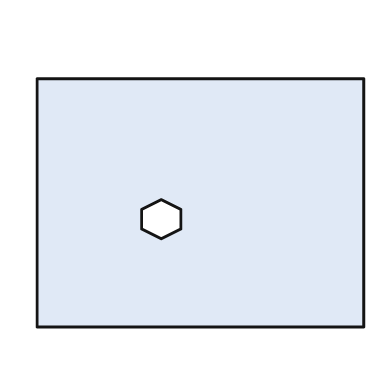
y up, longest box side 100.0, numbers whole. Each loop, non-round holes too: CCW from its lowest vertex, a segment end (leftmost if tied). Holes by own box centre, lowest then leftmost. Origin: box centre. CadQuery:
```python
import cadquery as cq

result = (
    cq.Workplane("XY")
    .moveTo(-50.0, -38.0)
    .lineTo(50.0, -38.0)
    .lineTo(50.0, 38.0)
    .lineTo(-50.0, 38.0)
    .close()
    .moveTo(-12.0, -11.0)
    .lineTo(-6.0, -8.0)
    .lineTo(-6.0, -2.0)
    .lineTo(-12.0, 1.0)
    .lineTo(-18.0, -2.0)
    .lineTo(-18.0, -8.0)
    .close()
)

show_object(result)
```